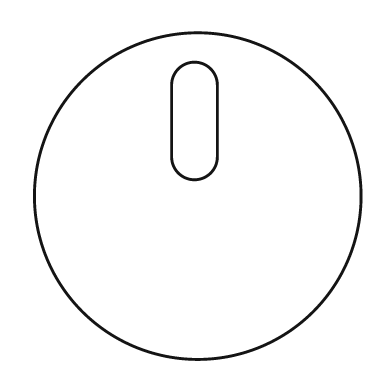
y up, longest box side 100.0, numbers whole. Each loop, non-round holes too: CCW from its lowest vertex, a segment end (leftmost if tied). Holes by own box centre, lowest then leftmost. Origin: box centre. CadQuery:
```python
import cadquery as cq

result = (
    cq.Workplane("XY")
    .moveTo(0.0, 0.0)
    .circle(50.0)
    .moveTo(-8.0, 12.0)
    .threePointArc((-1.0, 5.0), (6.0, 12.0))
    .lineTo(6.0, 34.0)
    .threePointArc((-1.0, 41.0), (-8.0, 34.0))
    .close()
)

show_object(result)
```